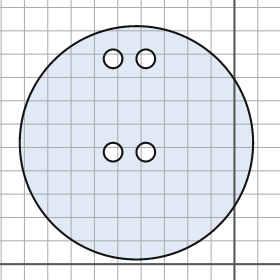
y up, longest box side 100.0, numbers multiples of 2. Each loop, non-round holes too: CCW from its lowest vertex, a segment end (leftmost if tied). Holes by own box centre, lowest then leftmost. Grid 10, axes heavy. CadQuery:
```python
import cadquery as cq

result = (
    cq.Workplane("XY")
    .moveTo(-42.0, 52.0)
    .circle(50.0)
    .moveTo(-52.0, 48.0)
    .circle(4.0)
    .moveTo(-38.0, 48.0)
    .circle(4.0)
    .moveTo(-52.0, 88.0)
    .circle(4.0)
    .moveTo(-38.0, 88.0)
    .circle(4.0)
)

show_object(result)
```